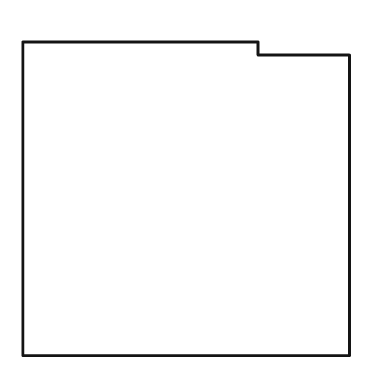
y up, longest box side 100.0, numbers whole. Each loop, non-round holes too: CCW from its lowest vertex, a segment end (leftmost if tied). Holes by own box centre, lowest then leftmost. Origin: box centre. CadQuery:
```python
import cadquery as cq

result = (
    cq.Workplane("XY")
    .moveTo(-50.0, -48.0)
    .lineTo(50.0, -48.0)
    .lineTo(50.0, 44.0)
    .lineTo(22.0, 44.0)
    .lineTo(22.0, 48.0)
    .lineTo(-50.0, 48.0)
    .close()
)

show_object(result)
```